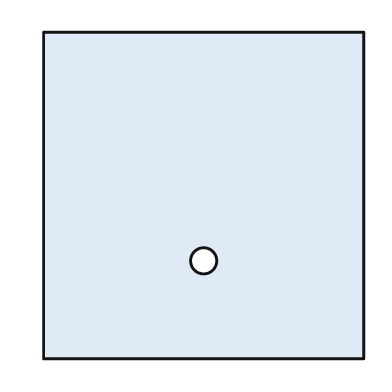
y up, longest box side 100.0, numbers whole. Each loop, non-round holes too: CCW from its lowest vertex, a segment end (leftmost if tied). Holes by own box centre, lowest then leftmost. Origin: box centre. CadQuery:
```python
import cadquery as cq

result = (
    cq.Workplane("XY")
    .moveTo(-49.0, -50.0)
    .lineTo(49.0, -50.0)
    .lineTo(49.0, 50.0)
    .lineTo(-49.0, 50.0)
    .close()
    .moveTo(0.0, -20.0)
    .circle(4.0)
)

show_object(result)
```